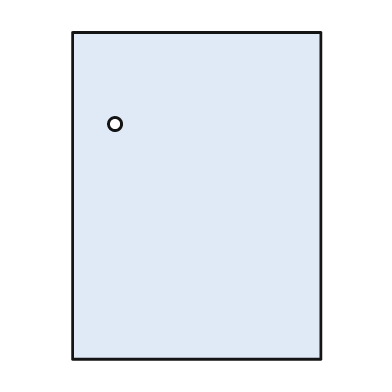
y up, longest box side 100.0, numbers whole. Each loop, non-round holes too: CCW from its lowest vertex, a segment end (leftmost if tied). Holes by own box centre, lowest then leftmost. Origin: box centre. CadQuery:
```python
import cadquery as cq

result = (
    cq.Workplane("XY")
    .moveTo(-38.0, -50.0)
    .lineTo(38.0, -50.0)
    .lineTo(38.0, 50.0)
    .lineTo(-38.0, 50.0)
    .close()
    .moveTo(-25.0, 22.0)
    .circle(2.0)
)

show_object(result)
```